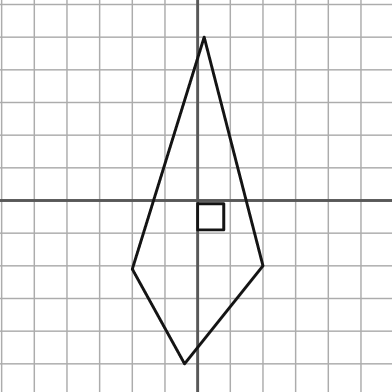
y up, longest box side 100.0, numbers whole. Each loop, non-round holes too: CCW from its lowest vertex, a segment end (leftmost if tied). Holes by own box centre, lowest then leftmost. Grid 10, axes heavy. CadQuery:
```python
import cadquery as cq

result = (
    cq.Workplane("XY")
    .moveTo(-4.0, -50.0)
    .lineTo(20.0, -20.0)
    .lineTo(2.0, 50.0)
    .lineTo(-20.0, -21.0)
    .close()
    .moveTo(0.0, -9.0)
    .lineTo(8.0, -9.0)
    .lineTo(8.0, -1.0)
    .lineTo(0.0, -1.0)
    .close()
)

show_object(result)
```